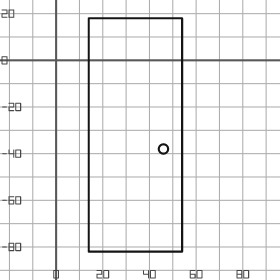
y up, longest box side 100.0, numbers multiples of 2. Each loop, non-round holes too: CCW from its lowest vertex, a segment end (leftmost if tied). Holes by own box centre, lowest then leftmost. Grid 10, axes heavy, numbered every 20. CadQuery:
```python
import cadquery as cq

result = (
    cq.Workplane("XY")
    .moveTo(14.0, -82.0)
    .lineTo(54.0, -82.0)
    .lineTo(54.0, 18.0)
    .lineTo(14.0, 18.0)
    .close()
    .moveTo(46.0, -38.0)
    .circle(2.0)
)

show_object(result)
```